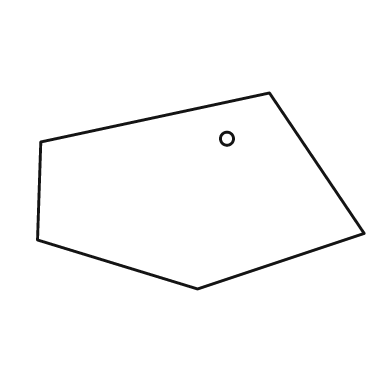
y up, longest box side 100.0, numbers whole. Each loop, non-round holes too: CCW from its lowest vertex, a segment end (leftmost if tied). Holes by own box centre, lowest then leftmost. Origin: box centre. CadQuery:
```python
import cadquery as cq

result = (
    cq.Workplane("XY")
    .moveTo(-1.0, -30.0)
    .lineTo(50.0, -13.0)
    .lineTo(21.0, 30.0)
    .lineTo(-49.0, 15.0)
    .lineTo(-50.0, -15.0)
    .close()
    .moveTo(8.0, 16.0)
    .circle(2.0)
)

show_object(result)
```